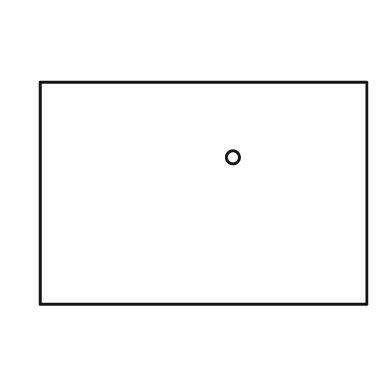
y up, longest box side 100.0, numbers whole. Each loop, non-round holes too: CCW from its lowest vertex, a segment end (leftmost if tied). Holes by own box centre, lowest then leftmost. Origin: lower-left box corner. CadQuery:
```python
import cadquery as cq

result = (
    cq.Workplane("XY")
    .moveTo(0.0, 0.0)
    .lineTo(100.0, 0.0)
    .lineTo(100.0, 68.0)
    .lineTo(0.0, 68.0)
    .close()
    .moveTo(59.0, 45.0)
    .circle(2.0)
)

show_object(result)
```